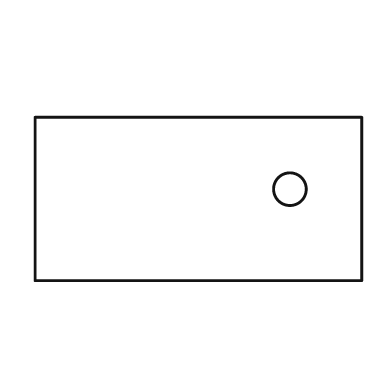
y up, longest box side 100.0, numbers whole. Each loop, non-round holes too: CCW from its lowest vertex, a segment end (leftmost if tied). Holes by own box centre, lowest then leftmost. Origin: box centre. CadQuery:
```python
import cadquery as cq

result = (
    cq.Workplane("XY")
    .moveTo(-50.0, -25.0)
    .lineTo(50.0, -25.0)
    .lineTo(50.0, 25.0)
    .lineTo(-50.0, 25.0)
    .close()
    .moveTo(28.0, 3.0)
    .circle(5.0)
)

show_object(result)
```